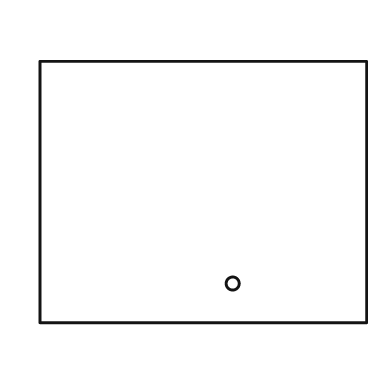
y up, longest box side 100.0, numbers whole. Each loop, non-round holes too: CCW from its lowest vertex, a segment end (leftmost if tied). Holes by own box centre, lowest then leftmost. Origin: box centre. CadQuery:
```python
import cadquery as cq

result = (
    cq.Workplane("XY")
    .moveTo(-50.0, -40.0)
    .lineTo(50.0, -40.0)
    .lineTo(50.0, 40.0)
    .lineTo(-50.0, 40.0)
    .close()
    .moveTo(9.0, -28.0)
    .circle(2.0)
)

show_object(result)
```